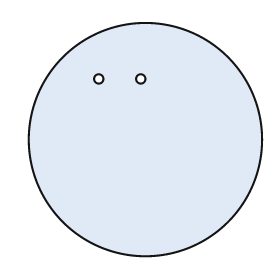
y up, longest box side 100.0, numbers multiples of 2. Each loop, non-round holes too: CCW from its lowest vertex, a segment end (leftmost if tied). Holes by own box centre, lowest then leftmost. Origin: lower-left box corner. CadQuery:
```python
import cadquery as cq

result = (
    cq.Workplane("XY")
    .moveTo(50.0, 50.0)
    .circle(50.0)
    .moveTo(30.0, 76.0)
    .circle(2.0)
    .moveTo(48.0, 76.0)
    .circle(2.0)
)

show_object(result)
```